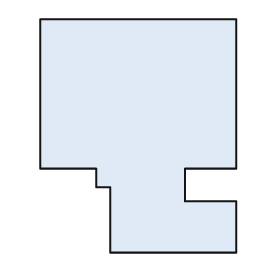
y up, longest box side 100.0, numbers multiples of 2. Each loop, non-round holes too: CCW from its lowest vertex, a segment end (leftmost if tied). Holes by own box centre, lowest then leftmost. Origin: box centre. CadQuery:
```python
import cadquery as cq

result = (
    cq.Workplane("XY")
    .moveTo(-12.0, -50.0)
    .lineTo(42.0, -50.0)
    .lineTo(42.0, -28.0)
    .lineTo(20.0, -28.0)
    .lineTo(20.0, -14.0)
    .lineTo(42.0, -14.0)
    .lineTo(42.0, 50.0)
    .lineTo(-42.0, 50.0)
    .lineTo(-42.0, -14.0)
    .lineTo(-18.0, -14.0)
    .lineTo(-18.0, -22.0)
    .lineTo(-12.0, -22.0)
    .close()
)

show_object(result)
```